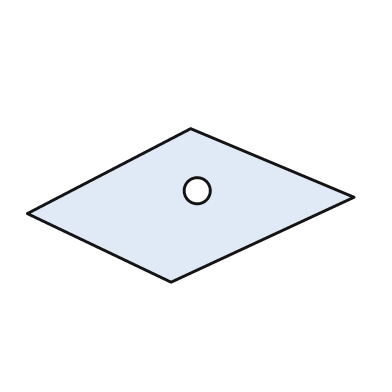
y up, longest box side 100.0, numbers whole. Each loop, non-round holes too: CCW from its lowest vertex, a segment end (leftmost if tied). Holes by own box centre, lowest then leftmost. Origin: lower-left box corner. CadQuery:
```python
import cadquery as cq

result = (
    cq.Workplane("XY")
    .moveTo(44.0, 0.0)
    .lineTo(100.0, 26.0)
    .lineTo(50.0, 47.0)
    .lineTo(0.0, 21.0)
    .close()
    .moveTo(52.0, 28.0)
    .circle(4.0)
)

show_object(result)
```